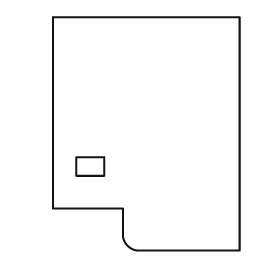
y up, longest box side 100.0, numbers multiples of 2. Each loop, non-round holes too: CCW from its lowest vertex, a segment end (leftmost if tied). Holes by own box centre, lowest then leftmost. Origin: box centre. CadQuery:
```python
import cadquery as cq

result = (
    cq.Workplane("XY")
    .moveTo(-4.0, -50.0)
    .lineTo(40.0, -50.0)
    .lineTo(40.0, 50.0)
    .lineTo(-40.0, 50.0)
    .lineTo(-40.0, -32.0)
    .lineTo(-10.0, -32.0)
    .lineTo(-10.0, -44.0)
    .threePointArc((-8.0, -48.0), (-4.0, -50.0))
    .close()
    .moveTo(-30.0, -18.0)
    .lineTo(-18.0, -18.0)
    .lineTo(-18.0, -10.0)
    .lineTo(-30.0, -10.0)
    .close()
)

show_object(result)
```